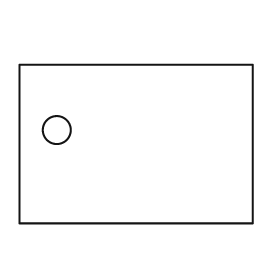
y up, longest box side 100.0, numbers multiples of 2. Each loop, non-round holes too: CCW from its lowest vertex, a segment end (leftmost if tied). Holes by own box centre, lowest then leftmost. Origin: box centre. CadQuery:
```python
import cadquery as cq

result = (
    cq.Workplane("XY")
    .moveTo(-50.0, -34.0)
    .lineTo(50.0, -34.0)
    .lineTo(50.0, 34.0)
    .lineTo(-50.0, 34.0)
    .close()
    .moveTo(-34.0, 6.0)
    .circle(6.0)
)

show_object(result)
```